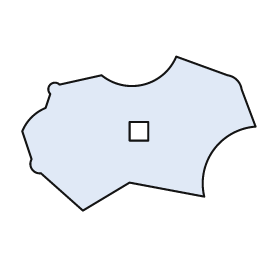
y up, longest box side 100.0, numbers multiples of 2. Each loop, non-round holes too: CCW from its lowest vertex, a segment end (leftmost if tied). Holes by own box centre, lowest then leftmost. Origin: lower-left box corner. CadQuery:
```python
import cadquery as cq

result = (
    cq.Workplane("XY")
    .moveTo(26.0, 0.0)
    .lineTo(46.0, 12.0)
    .lineTo(78.0, 6.0)
    .threePointArc((82.0, 26.0), (100.0, 36.0))
    .lineTo(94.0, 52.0)
    .threePointArc((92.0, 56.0), (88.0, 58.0))
    .lineTo(66.0, 66.0)
    .threePointArc((52.0, 54.0), (34.0, 58.0))
    .lineTo(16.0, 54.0)
    .threePointArc((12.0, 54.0), (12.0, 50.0))
    .lineTo(10.0, 44.0)
    .threePointArc((4.0, 40.0), (0.0, 34.0))
    .lineTo(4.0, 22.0)
    .threePointArc((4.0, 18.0), (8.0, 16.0))
    .close()
    .moveTo(46.0, 30.0)
    .lineTo(54.0, 30.0)
    .lineTo(54.0, 38.0)
    .lineTo(46.0, 38.0)
    .close()
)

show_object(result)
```